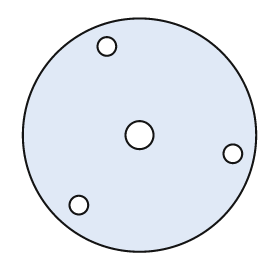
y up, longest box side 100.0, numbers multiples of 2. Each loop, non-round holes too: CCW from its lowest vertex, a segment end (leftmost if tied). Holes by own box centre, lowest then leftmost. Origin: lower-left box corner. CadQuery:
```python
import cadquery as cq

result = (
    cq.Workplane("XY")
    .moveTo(50.0, 50.0)
    .circle(50.0)
    .moveTo(24.0, 20.0)
    .circle(4.0)
    .moveTo(90.0, 42.0)
    .circle(4.0)
    .moveTo(50.0, 50.0)
    .circle(6.0)
    .moveTo(36.0, 88.0)
    .circle(4.0)
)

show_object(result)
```